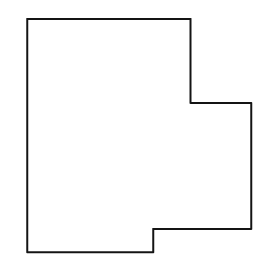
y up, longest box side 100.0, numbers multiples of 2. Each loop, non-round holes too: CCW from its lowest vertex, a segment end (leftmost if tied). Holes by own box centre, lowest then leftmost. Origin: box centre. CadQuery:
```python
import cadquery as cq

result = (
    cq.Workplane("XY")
    .moveTo(-48.0, -50.0)
    .lineTo(6.0, -50.0)
    .lineTo(6.0, -40.0)
    .lineTo(48.0, -40.0)
    .lineTo(48.0, 14.0)
    .lineTo(22.0, 14.0)
    .lineTo(22.0, 50.0)
    .lineTo(-48.0, 50.0)
    .close()
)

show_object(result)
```